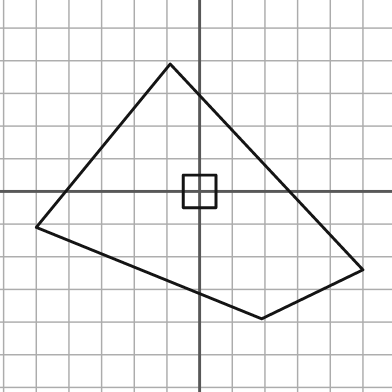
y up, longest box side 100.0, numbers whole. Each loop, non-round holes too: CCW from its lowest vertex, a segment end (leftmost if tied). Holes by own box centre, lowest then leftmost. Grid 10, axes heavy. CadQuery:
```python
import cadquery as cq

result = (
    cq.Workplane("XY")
    .moveTo(19.0, -39.0)
    .lineTo(50.0, -24.0)
    .lineTo(-9.0, 39.0)
    .lineTo(-50.0, -11.0)
    .close()
    .moveTo(-5.0, -5.0)
    .lineTo(5.0, -5.0)
    .lineTo(5.0, 5.0)
    .lineTo(-5.0, 5.0)
    .close()
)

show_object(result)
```